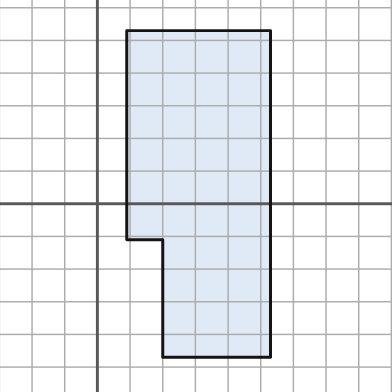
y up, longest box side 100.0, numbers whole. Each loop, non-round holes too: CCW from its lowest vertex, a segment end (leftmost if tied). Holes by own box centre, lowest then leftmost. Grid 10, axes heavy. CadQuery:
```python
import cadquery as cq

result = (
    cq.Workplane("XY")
    .moveTo(20.0, -47.0)
    .lineTo(53.0, -47.0)
    .lineTo(53.0, 53.0)
    .lineTo(9.0, 53.0)
    .lineTo(9.0, -11.0)
    .lineTo(20.0, -11.0)
    .close()
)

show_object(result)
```